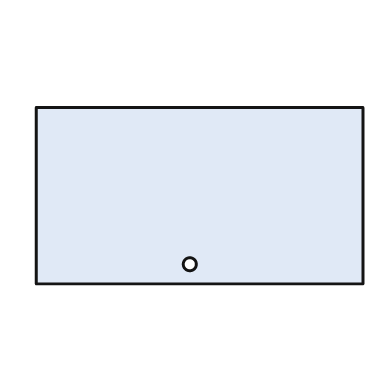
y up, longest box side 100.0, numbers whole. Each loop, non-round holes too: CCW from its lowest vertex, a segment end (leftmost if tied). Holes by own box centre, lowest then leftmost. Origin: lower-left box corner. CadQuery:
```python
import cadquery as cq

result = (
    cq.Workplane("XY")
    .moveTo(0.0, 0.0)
    .lineTo(100.0, 0.0)
    .lineTo(100.0, 54.0)
    .lineTo(0.0, 54.0)
    .close()
    .moveTo(47.0, 6.0)
    .circle(2.0)
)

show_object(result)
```